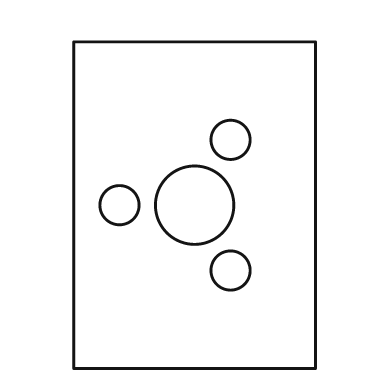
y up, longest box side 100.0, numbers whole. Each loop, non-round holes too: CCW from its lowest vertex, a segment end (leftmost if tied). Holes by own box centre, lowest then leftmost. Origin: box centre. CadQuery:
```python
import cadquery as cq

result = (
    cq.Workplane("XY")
    .moveTo(-37.0, -50.0)
    .lineTo(37.0, -50.0)
    .lineTo(37.0, 50.0)
    .lineTo(-37.0, 50.0)
    .close()
    .moveTo(11.0, -20.0)
    .circle(6.0)
    .moveTo(-23.0, 0.0)
    .circle(6.0)
    .moveTo(0.0, 0.0)
    .circle(12.0)
    .moveTo(11.0, 20.0)
    .circle(6.0)
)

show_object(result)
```